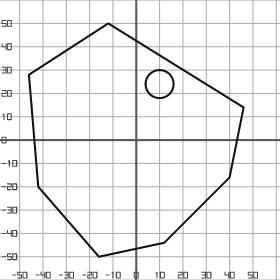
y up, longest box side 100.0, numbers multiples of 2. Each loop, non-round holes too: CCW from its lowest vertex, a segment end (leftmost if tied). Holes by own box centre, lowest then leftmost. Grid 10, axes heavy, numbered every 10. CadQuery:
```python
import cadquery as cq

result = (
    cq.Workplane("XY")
    .moveTo(-16.0, -50.0)
    .lineTo(12.0, -44.0)
    .lineTo(40.0, -16.0)
    .lineTo(46.0, 14.0)
    .lineTo(-12.0, 50.0)
    .lineTo(-46.0, 28.0)
    .lineTo(-42.0, -20.0)
    .close()
    .moveTo(10.0, 24.0)
    .circle(6.0)
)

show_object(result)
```